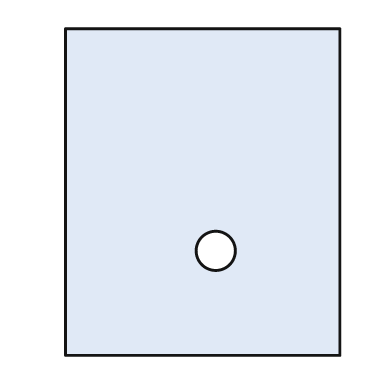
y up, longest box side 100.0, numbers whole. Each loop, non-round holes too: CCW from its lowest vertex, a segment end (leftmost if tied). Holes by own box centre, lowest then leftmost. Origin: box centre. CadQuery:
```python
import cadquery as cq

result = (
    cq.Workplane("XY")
    .moveTo(-42.0, -50.0)
    .lineTo(42.0, -50.0)
    .lineTo(42.0, 50.0)
    .lineTo(-42.0, 50.0)
    .close()
    .moveTo(4.0, -18.0)
    .circle(6.0)
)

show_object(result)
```